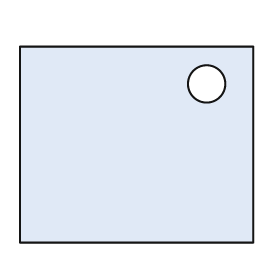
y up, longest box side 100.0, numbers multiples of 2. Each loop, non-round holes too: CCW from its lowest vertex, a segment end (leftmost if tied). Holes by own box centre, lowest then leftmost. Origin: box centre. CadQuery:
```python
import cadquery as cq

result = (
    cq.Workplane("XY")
    .moveTo(-50.0, -42.0)
    .lineTo(50.0, -42.0)
    .lineTo(50.0, 42.0)
    .lineTo(-50.0, 42.0)
    .close()
    .moveTo(30.0, 26.0)
    .circle(8.0)
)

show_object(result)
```